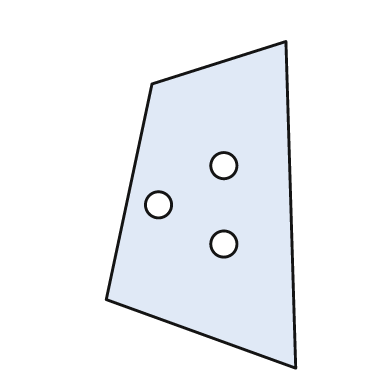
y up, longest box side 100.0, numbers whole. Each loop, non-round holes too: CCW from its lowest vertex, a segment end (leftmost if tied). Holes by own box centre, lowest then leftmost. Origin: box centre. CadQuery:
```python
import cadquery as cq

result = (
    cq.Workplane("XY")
    .moveTo(29.0, -50.0)
    .lineTo(26.0, 50.0)
    .lineTo(-15.0, 37.0)
    .lineTo(-29.0, -29.0)
    .close()
    .moveTo(7.0, -12.0)
    .circle(4.0)
    .moveTo(-13.0, 0.0)
    .circle(4.0)
    .moveTo(7.0, 12.0)
    .circle(4.0)
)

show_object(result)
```